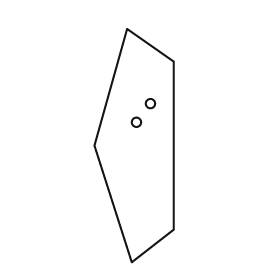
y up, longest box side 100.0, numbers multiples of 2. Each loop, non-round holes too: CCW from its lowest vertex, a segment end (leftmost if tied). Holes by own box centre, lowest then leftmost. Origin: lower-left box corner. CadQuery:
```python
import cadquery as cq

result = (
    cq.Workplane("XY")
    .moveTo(16.0, 0.0)
    .lineTo(34.0, 14.0)
    .lineTo(34.0, 86.0)
    .lineTo(14.0, 100.0)
    .lineTo(0.0, 50.0)
    .close()
    .moveTo(18.0, 60.0)
    .circle(2.0)
    .moveTo(24.0, 68.0)
    .circle(2.0)
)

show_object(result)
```